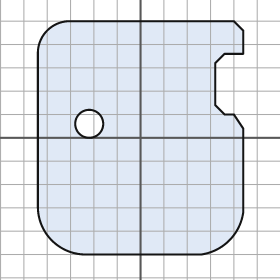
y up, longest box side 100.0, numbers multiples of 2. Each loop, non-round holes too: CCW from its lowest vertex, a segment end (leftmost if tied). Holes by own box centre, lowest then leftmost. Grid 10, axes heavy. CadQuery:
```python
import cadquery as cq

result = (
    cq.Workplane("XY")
    .moveTo(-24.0, -50.0)
    .lineTo(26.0, -50.0)
    .threePointArc((38.0, -44.0), (44.0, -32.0))
    .lineTo(44.0, 4.0)
    .lineTo(40.0, 10.0)
    .lineTo(36.0, 10.0)
    .lineTo(32.0, 14.0)
    .lineTo(32.0, 32.0)
    .lineTo(36.0, 36.0)
    .lineTo(44.0, 36.0)
    .lineTo(44.0, 46.0)
    .lineTo(40.0, 50.0)
    .lineTo(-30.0, 50.0)
    .threePointArc((-40.0, 46.0), (-44.0, 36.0))
    .lineTo(-44.0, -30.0)
    .threePointArc((-38.0, -44.0), (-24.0, -50.0))
    .close()
    .moveTo(-22.0, 6.0)
    .circle(6.0)
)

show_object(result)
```